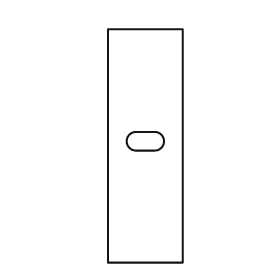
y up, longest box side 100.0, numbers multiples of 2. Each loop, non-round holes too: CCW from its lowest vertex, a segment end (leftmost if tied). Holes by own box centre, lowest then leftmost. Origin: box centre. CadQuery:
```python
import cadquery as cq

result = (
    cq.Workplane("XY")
    .moveTo(-16.0, -50.0)
    .lineTo(16.0, -50.0)
    .lineTo(16.0, 50.0)
    .lineTo(-16.0, 50.0)
    .close()
    .moveTo(-4.0, -2.0)
    .lineTo(4.0, -2.0)
    .threePointArc((8.0, 2.0), (4.0, 6.0))
    .lineTo(-4.0, 6.0)
    .threePointArc((-8.0, 2.0), (-4.0, -2.0))
    .close()
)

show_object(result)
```